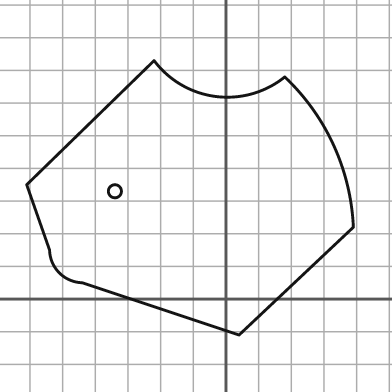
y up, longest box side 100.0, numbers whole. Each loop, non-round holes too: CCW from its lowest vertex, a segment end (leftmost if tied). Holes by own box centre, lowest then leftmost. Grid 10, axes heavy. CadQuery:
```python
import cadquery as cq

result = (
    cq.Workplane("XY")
    .moveTo(4.0, -11.0)
    .lineTo(39.0, 22.0)
    .threePointArc((33.0, 47.0), (18.0, 68.0))
    .threePointArc((-3.0, 62.0), (-22.0, 73.0))
    .lineTo(-61.0, 35.0)
    .lineTo(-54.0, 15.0)
    .threePointArc((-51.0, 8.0), (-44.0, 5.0))
    .close()
    .moveTo(-34.0, 33.0)
    .circle(2.0)
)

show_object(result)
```